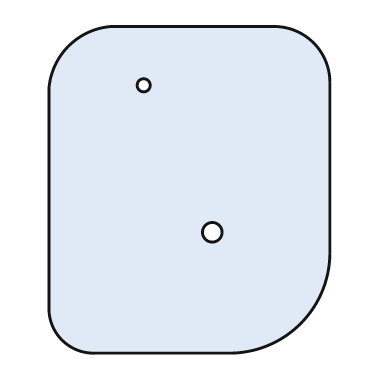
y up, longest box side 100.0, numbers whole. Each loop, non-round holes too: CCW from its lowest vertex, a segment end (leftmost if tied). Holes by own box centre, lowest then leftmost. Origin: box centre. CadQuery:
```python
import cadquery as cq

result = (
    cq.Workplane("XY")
    .moveTo(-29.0, -50.0)
    .lineTo(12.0, -50.0)
    .threePointArc((34.0, -41.0), (43.0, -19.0))
    .lineTo(43.0, 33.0)
    .threePointArc((38.0, 45.0), (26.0, 50.0))
    .lineTo(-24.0, 50.0)
    .threePointArc((-37.0, 44.0), (-43.0, 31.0))
    .lineTo(-43.0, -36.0)
    .threePointArc((-39.0, -46.0), (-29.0, -50.0))
    .close()
    .moveTo(7.0, -13.0)
    .circle(3.0)
    .moveTo(-14.0, 32.0)
    .circle(2.0)
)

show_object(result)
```